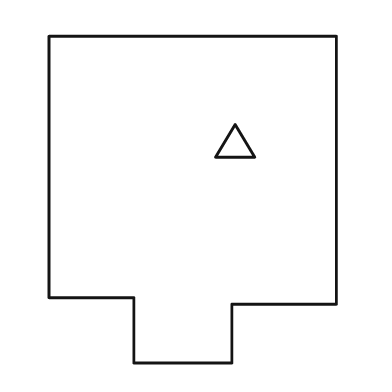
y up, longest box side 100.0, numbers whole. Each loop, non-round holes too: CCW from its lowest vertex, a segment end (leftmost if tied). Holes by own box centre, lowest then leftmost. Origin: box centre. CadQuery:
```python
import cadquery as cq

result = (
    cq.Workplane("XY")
    .moveTo(-18.0, -50.0)
    .lineTo(12.0, -50.0)
    .lineTo(12.0, -32.0)
    .lineTo(44.0, -32.0)
    .lineTo(44.0, 50.0)
    .lineTo(-44.0, 50.0)
    .lineTo(-44.0, -30.0)
    .lineTo(-18.0, -30.0)
    .close()
    .moveTo(7.0, 13.0)
    .lineTo(19.0, 13.0)
    .lineTo(13.0, 23.0)
    .close()
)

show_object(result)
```